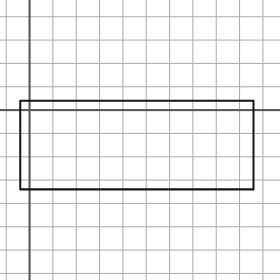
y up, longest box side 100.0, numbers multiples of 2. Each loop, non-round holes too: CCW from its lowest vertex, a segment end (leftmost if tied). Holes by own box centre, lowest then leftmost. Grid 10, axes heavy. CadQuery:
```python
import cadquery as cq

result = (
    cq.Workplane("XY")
    .moveTo(-4.0, -34.0)
    .lineTo(96.0, -34.0)
    .lineTo(96.0, 4.0)
    .lineTo(-4.0, 4.0)
    .close()
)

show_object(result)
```